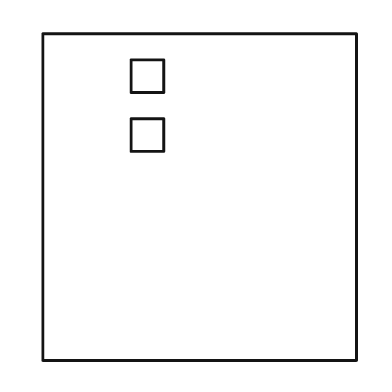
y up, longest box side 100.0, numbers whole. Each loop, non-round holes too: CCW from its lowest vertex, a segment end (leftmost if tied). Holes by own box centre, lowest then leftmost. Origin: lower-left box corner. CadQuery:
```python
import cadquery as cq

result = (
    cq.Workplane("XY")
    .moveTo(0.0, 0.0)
    .lineTo(96.0, 0.0)
    .lineTo(96.0, 100.0)
    .lineTo(0.0, 100.0)
    .close()
    .moveTo(27.0, 64.0)
    .lineTo(37.0, 64.0)
    .lineTo(37.0, 74.0)
    .lineTo(27.0, 74.0)
    .close()
    .moveTo(27.0, 82.0)
    .lineTo(37.0, 82.0)
    .lineTo(37.0, 92.0)
    .lineTo(27.0, 92.0)
    .close()
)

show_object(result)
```